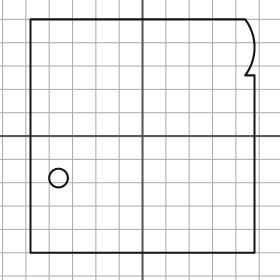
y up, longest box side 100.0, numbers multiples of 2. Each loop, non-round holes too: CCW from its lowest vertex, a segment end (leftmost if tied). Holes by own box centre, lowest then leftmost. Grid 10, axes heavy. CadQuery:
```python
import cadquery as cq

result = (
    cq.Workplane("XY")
    .moveTo(-48.0, -50.0)
    .lineTo(48.0, -50.0)
    .lineTo(48.0, 26.0)
    .lineTo(44.0, 26.0)
    .threePointArc((48.0, 38.0), (44.0, 50.0))
    .lineTo(-48.0, 50.0)
    .close()
    .moveTo(-36.0, -18.0)
    .circle(4.0)
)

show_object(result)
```